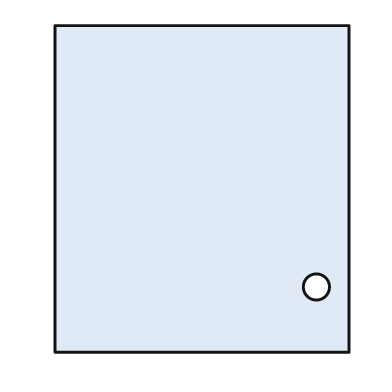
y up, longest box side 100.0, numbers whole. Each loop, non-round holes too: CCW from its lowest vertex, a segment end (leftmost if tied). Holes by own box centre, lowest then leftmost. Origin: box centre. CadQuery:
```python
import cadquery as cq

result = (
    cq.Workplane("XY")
    .moveTo(-45.0, -50.0)
    .lineTo(45.0, -50.0)
    .lineTo(45.0, 50.0)
    .lineTo(-45.0, 50.0)
    .close()
    .moveTo(35.0, -30.0)
    .circle(4.0)
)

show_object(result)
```